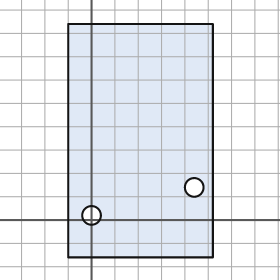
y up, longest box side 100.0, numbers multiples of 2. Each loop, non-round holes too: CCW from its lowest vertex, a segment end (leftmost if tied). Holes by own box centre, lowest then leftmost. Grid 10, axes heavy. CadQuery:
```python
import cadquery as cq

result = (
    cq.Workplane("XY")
    .moveTo(-10.0, -16.0)
    .lineTo(52.0, -16.0)
    .lineTo(52.0, 84.0)
    .lineTo(-10.0, 84.0)
    .close()
    .moveTo(0.0, 2.0)
    .circle(4.0)
    .moveTo(44.0, 14.0)
    .circle(4.0)
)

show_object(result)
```